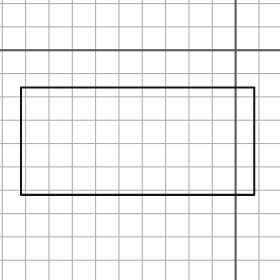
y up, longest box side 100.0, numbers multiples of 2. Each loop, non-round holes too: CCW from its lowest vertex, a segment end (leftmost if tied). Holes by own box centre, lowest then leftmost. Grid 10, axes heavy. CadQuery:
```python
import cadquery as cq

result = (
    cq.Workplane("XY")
    .moveTo(-92.0, -62.0)
    .lineTo(8.0, -62.0)
    .lineTo(8.0, -16.0)
    .lineTo(-92.0, -16.0)
    .close()
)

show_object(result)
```